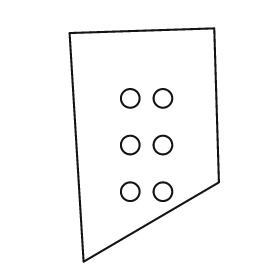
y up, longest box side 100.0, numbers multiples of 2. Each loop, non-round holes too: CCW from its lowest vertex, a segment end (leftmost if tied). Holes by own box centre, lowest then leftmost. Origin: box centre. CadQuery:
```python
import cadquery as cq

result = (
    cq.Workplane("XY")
    .moveTo(-26.0, -50.0)
    .lineTo(32.0, -16.0)
    .lineTo(30.0, 50.0)
    .lineTo(-32.0, 48.0)
    .close()
    .moveTo(-6.0, -20.0)
    .circle(4.0)
    .moveTo(8.0, -20.0)
    .circle(4.0)
    .moveTo(-6.0, 0.0)
    .circle(4.0)
    .moveTo(8.0, 0.0)
    .circle(4.0)
    .moveTo(-6.0, 20.0)
    .circle(4.0)
    .moveTo(8.0, 20.0)
    .circle(4.0)
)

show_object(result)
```